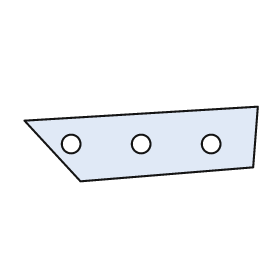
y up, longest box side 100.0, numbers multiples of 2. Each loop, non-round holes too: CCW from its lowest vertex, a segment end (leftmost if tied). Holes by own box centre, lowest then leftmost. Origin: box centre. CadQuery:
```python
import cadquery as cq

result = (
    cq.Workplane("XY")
    .moveTo(-26.0, -16.0)
    .lineTo(48.0, -10.0)
    .lineTo(50.0, 16.0)
    .lineTo(-50.0, 10.0)
    .close()
    .moveTo(-30.0, 0.0)
    .circle(4.0)
    .moveTo(0.0, 0.0)
    .circle(4.0)
    .moveTo(30.0, 0.0)
    .circle(4.0)
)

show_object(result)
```